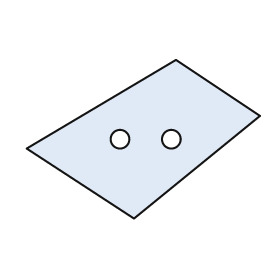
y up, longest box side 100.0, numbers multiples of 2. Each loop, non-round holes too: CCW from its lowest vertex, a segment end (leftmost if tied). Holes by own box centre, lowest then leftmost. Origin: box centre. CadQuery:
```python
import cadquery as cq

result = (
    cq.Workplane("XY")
    .moveTo(-4.0, -34.0)
    .lineTo(50.0, 10.0)
    .lineTo(14.0, 34.0)
    .lineTo(-50.0, -4.0)
    .close()
    .moveTo(-10.0, 0.0)
    .circle(4.0)
    .moveTo(12.0, 0.0)
    .circle(4.0)
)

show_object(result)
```